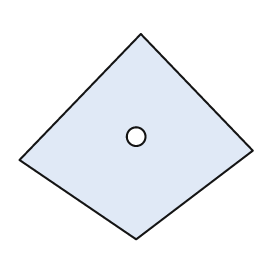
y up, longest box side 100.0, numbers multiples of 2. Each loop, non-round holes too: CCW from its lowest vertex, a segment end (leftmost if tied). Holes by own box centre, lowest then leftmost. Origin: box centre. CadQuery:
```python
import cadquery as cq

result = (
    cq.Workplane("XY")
    .moveTo(0.0, -44.0)
    .lineTo(50.0, -6.0)
    .lineTo(2.0, 44.0)
    .lineTo(-50.0, -10.0)
    .close()
    .moveTo(0.0, 0.0)
    .circle(4.0)
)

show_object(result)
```